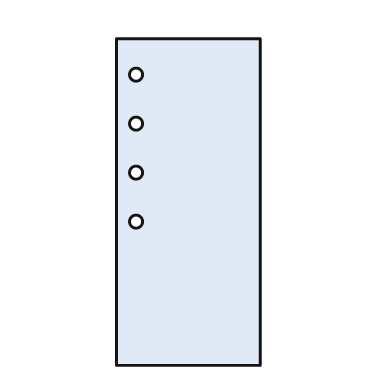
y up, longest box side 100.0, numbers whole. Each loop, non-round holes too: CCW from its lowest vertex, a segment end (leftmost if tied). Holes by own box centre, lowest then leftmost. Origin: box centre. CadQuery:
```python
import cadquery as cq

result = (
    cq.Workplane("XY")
    .moveTo(-22.0, -50.0)
    .lineTo(22.0, -50.0)
    .lineTo(22.0, 50.0)
    .lineTo(-22.0, 50.0)
    .close()
    .moveTo(-16.0, -6.0)
    .circle(2.0)
    .moveTo(-16.0, 9.0)
    .circle(2.0)
    .moveTo(-16.0, 24.0)
    .circle(2.0)
    .moveTo(-16.0, 39.0)
    .circle(2.0)
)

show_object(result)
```